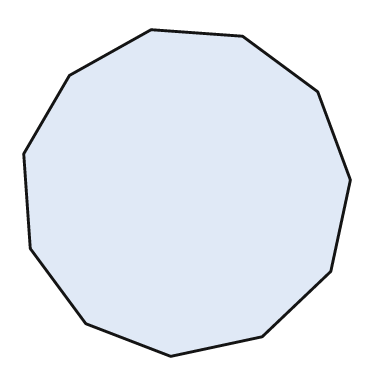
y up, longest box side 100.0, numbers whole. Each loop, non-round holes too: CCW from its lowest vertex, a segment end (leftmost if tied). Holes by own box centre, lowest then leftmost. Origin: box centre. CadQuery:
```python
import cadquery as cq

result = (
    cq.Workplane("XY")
    .moveTo(-5.0, -50.0)
    .lineTo(23.0, -44.0)
    .lineTo(44.0, -24.0)
    .lineTo(50.0, 4.0)
    .lineTo(40.0, 31.0)
    .lineTo(17.0, 48.0)
    .lineTo(-11.0, 50.0)
    .lineTo(-36.0, 36.0)
    .lineTo(-50.0, 12.0)
    .lineTo(-48.0, -17.0)
    .lineTo(-31.0, -40.0)
    .close()
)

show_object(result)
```